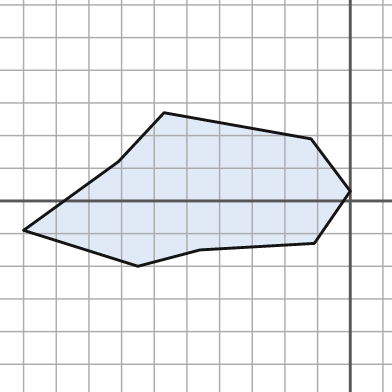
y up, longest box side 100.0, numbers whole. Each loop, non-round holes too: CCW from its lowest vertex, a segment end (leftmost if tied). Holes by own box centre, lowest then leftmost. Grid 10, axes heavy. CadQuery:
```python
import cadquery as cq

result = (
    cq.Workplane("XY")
    .moveTo(-65.0, -20.0)
    .lineTo(-46.0, -15.0)
    .lineTo(-11.0, -13.0)
    .lineTo(0.0, 3.0)
    .lineTo(-12.0, 19.0)
    .lineTo(-57.0, 27.0)
    .lineTo(-71.0, 12.0)
    .lineTo(-100.0, -9.0)
    .close()
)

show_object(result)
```